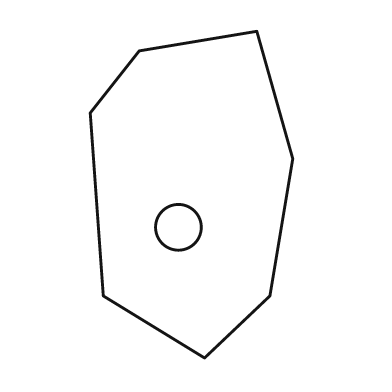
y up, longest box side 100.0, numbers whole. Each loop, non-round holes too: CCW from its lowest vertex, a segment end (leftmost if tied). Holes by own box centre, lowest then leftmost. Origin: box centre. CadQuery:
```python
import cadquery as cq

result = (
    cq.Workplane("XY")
    .moveTo(4.0, -50.0)
    .lineTo(24.0, -31.0)
    .lineTo(31.0, 11.0)
    .lineTo(20.0, 50.0)
    .lineTo(-16.0, 44.0)
    .lineTo(-31.0, 25.0)
    .lineTo(-27.0, -31.0)
    .close()
    .moveTo(-4.0, -10.0)
    .circle(7.0)
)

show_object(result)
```